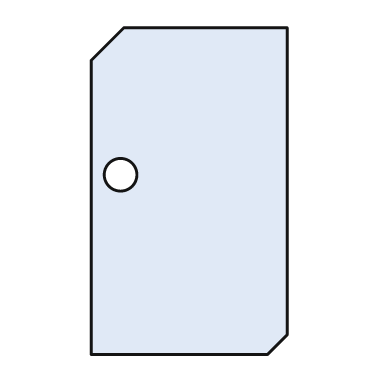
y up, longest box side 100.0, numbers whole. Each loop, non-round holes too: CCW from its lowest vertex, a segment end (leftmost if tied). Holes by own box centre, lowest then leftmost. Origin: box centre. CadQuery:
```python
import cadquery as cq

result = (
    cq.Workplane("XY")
    .moveTo(-30.0, -50.0)
    .lineTo(24.0, -50.0)
    .lineTo(30.0, -44.0)
    .lineTo(30.0, 50.0)
    .lineTo(-20.0, 50.0)
    .lineTo(-30.0, 40.0)
    .close()
    .moveTo(-21.0, 5.0)
    .circle(5.0)
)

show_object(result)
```